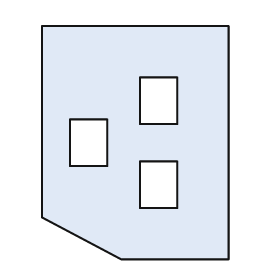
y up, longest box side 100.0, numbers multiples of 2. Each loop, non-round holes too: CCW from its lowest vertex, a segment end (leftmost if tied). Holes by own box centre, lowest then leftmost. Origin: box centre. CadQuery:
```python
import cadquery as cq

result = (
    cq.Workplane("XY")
    .moveTo(-6.0, -50.0)
    .lineTo(40.0, -50.0)
    .lineTo(40.0, 50.0)
    .lineTo(-40.0, 50.0)
    .lineTo(-40.0, -32.0)
    .close()
    .moveTo(2.0, -28.0)
    .lineTo(18.0, -28.0)
    .lineTo(18.0, -8.0)
    .lineTo(2.0, -8.0)
    .close()
    .moveTo(-28.0, -10.0)
    .lineTo(-12.0, -10.0)
    .lineTo(-12.0, 10.0)
    .lineTo(-28.0, 10.0)
    .close()
    .moveTo(2.0, 8.0)
    .lineTo(18.0, 8.0)
    .lineTo(18.0, 28.0)
    .lineTo(2.0, 28.0)
    .close()
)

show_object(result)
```